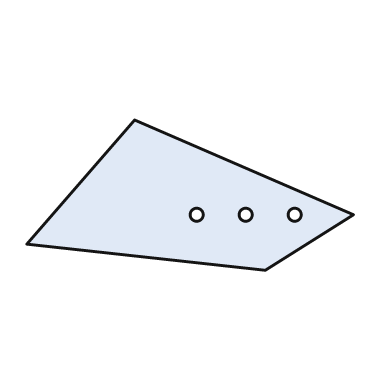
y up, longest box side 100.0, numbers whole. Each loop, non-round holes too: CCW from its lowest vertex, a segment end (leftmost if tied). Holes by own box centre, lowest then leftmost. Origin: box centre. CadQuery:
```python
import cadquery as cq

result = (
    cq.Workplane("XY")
    .moveTo(23.0, -23.0)
    .lineTo(50.0, -6.0)
    .lineTo(-17.0, 23.0)
    .lineTo(-50.0, -15.0)
    .close()
    .moveTo(2.0, -6.0)
    .circle(2.0)
    .moveTo(17.0, -6.0)
    .circle(2.0)
    .moveTo(32.0, -6.0)
    .circle(2.0)
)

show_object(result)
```